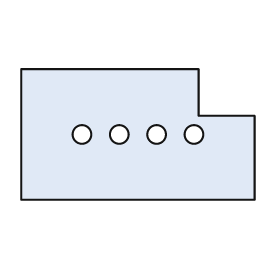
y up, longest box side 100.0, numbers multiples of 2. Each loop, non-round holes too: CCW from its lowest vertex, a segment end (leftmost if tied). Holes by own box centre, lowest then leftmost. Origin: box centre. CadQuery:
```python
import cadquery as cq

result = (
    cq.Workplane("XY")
    .moveTo(-50.0, -28.0)
    .lineTo(50.0, -28.0)
    .lineTo(50.0, 8.0)
    .lineTo(26.0, 8.0)
    .lineTo(26.0, 28.0)
    .lineTo(-50.0, 28.0)
    .close()
    .moveTo(-24.0, 0.0)
    .circle(4.0)
    .moveTo(-8.0, 0.0)
    .circle(4.0)
    .moveTo(8.0, 0.0)
    .circle(4.0)
    .moveTo(24.0, 0.0)
    .circle(4.0)
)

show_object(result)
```